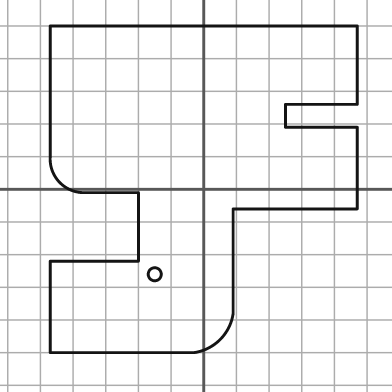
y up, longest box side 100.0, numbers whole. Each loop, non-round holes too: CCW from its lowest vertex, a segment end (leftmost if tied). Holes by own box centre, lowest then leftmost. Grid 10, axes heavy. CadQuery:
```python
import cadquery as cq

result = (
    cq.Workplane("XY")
    .moveTo(-47.0, -50.0)
    .lineTo(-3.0, -50.0)
    .threePointArc((5.0, -46.0), (9.0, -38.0))
    .lineTo(9.0, -6.0)
    .lineTo(47.0, -6.0)
    .lineTo(47.0, 19.0)
    .lineTo(25.0, 19.0)
    .lineTo(25.0, 26.0)
    .lineTo(47.0, 26.0)
    .lineTo(47.0, 50.0)
    .lineTo(-47.0, 50.0)
    .lineTo(-47.0, 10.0)
    .threePointArc((-44.0, 2.0), (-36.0, -1.0))
    .lineTo(-20.0, -1.0)
    .lineTo(-20.0, -22.0)
    .lineTo(-47.0, -22.0)
    .close()
    .moveTo(-15.0, -26.0)
    .circle(2.0)
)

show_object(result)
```